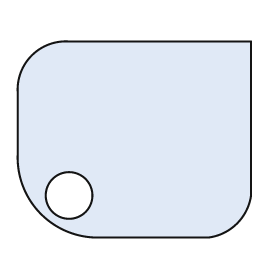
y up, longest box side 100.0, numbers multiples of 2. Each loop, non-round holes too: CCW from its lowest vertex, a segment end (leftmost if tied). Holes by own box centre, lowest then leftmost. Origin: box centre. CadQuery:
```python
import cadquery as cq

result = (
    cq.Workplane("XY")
    .moveTo(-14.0, -42.0)
    .lineTo(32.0, -42.0)
    .threePointArc((44.0, -36.0), (50.0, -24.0))
    .lineTo(50.0, 42.0)
    .lineTo(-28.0, 42.0)
    .threePointArc((-44.0, 36.0), (-50.0, 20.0))
    .lineTo(-50.0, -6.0)
    .threePointArc((-40.0, -32.0), (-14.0, -42.0))
    .close()
    .moveTo(-28.0, -24.0)
    .circle(10.0)
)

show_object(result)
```